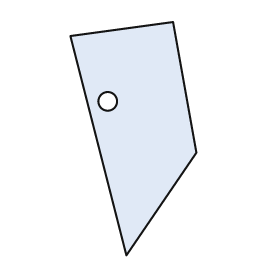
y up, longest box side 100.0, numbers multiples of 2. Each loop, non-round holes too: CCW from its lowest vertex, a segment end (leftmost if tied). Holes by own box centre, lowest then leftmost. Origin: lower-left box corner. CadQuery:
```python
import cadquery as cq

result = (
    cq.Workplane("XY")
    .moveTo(24.0, 0.0)
    .lineTo(54.0, 44.0)
    .lineTo(44.0, 100.0)
    .lineTo(0.0, 94.0)
    .close()
    .moveTo(16.0, 66.0)
    .circle(4.0)
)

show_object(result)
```